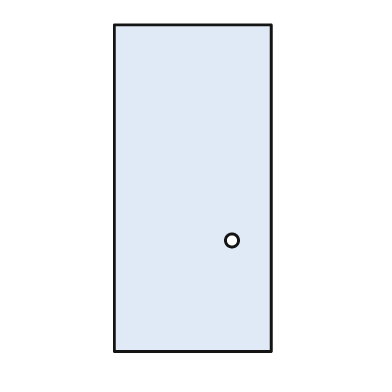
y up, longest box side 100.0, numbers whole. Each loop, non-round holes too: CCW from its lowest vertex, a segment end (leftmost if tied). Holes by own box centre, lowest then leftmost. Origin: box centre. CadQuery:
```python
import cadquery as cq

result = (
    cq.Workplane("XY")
    .moveTo(-24.0, -50.0)
    .lineTo(24.0, -50.0)
    .lineTo(24.0, 50.0)
    .lineTo(-24.0, 50.0)
    .close()
    .moveTo(12.0, -16.0)
    .circle(2.0)
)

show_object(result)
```